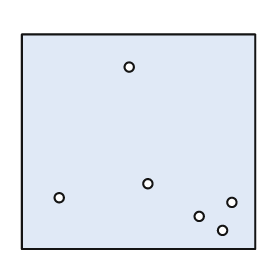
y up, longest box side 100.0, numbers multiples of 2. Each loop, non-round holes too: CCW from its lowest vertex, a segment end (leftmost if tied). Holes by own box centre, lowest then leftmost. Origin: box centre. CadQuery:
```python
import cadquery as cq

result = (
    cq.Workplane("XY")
    .moveTo(-50.0, -46.0)
    .lineTo(50.0, -46.0)
    .lineTo(50.0, 46.0)
    .lineTo(-50.0, 46.0)
    .close()
    .moveTo(36.0, -38.0)
    .circle(2.0)
    .moveTo(26.0, -32.0)
    .circle(2.0)
    .moveTo(40.0, -26.0)
    .circle(2.0)
    .moveTo(-34.0, -24.0)
    .circle(2.0)
    .moveTo(4.0, -18.0)
    .circle(2.0)
    .moveTo(-4.0, 32.0)
    .circle(2.0)
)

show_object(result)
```